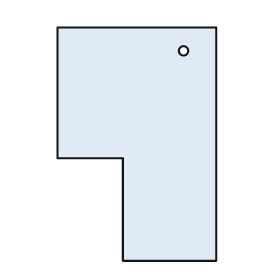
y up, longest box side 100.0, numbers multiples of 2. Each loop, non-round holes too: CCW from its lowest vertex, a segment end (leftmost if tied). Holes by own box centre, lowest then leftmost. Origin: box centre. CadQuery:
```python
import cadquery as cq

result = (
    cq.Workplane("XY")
    .moveTo(-6.0, -50.0)
    .lineTo(34.0, -50.0)
    .lineTo(34.0, 50.0)
    .lineTo(-34.0, 50.0)
    .lineTo(-34.0, -6.0)
    .lineTo(-6.0, -6.0)
    .close()
    .moveTo(20.0, 40.0)
    .circle(2.0)
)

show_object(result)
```